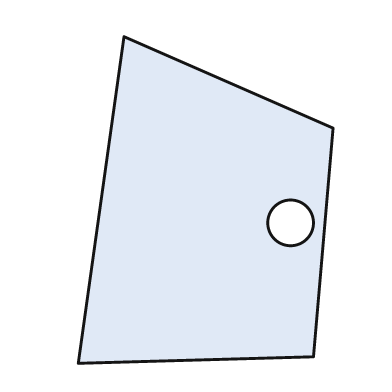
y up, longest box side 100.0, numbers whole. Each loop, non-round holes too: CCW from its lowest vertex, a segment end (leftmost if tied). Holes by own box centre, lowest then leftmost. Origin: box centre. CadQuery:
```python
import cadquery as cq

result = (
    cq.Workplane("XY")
    .moveTo(-39.0, -50.0)
    .lineTo(33.0, -48.0)
    .lineTo(39.0, 22.0)
    .lineTo(-25.0, 50.0)
    .close()
    .moveTo(26.0, -7.0)
    .circle(7.0)
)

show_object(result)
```